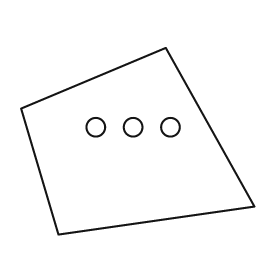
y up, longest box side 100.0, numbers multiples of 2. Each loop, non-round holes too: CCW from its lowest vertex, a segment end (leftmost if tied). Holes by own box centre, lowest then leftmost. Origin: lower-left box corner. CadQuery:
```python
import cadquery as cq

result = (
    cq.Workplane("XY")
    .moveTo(16.0, 0.0)
    .lineTo(100.0, 12.0)
    .lineTo(62.0, 80.0)
    .lineTo(0.0, 54.0)
    .close()
    .moveTo(32.0, 46.0)
    .circle(4.0)
    .moveTo(48.0, 46.0)
    .circle(4.0)
    .moveTo(64.0, 46.0)
    .circle(4.0)
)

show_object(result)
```